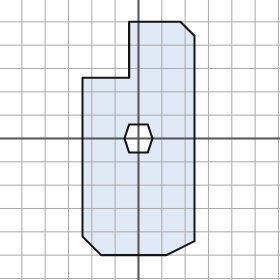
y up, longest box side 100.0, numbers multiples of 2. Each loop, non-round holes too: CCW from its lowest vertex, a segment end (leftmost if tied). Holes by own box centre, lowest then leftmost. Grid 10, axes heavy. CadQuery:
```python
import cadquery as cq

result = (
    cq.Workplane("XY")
    .moveTo(-16.0, -50.0)
    .lineTo(12.0, -50.0)
    .lineTo(24.0, -44.0)
    .lineTo(24.0, 44.0)
    .lineTo(18.0, 50.0)
    .lineTo(-4.0, 50.0)
    .lineTo(-4.0, 26.0)
    .lineTo(-24.0, 26.0)
    .lineTo(-24.0, -42.0)
    .close()
    .moveTo(-4.0, -6.0)
    .lineTo(4.0, -6.0)
    .lineTo(6.0, 0.0)
    .lineTo(4.0, 6.0)
    .lineTo(-4.0, 6.0)
    .lineTo(-6.0, 0.0)
    .close()
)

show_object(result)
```